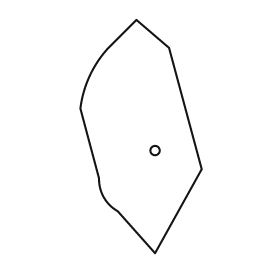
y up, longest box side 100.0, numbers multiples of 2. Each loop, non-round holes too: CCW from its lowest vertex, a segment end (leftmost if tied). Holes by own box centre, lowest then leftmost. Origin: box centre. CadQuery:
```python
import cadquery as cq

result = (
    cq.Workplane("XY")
    .moveTo(6.0, -50.0)
    .lineTo(26.0, -14.0)
    .lineTo(12.0, 38.0)
    .lineTo(-2.0, 50.0)
    .lineTo(-14.0, 38.0)
    .threePointArc((-22.0, 26.0), (-26.0, 12.0))
    .lineTo(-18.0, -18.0)
    .threePointArc((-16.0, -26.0), (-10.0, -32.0))
    .close()
    .moveTo(6.0, -6.0)
    .circle(2.0)
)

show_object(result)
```